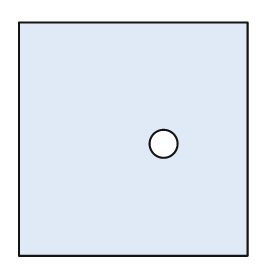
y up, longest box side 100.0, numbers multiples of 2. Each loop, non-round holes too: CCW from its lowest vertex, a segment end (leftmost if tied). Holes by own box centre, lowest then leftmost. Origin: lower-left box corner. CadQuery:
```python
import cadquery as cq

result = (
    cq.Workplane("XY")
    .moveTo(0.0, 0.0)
    .lineTo(98.0, 0.0)
    .lineTo(98.0, 100.0)
    .lineTo(0.0, 100.0)
    .close()
    .moveTo(62.0, 48.0)
    .circle(6.0)
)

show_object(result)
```